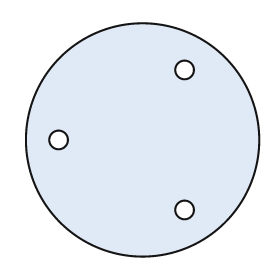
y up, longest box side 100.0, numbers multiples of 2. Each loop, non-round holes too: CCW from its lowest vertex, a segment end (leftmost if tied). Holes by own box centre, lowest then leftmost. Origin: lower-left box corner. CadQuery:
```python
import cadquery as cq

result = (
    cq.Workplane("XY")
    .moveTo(50.0, 50.0)
    .circle(50.0)
    .moveTo(68.0, 20.0)
    .circle(4.0)
    .moveTo(14.0, 50.0)
    .circle(4.0)
    .moveTo(68.0, 80.0)
    .circle(4.0)
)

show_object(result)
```